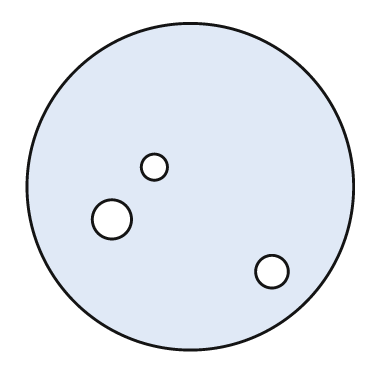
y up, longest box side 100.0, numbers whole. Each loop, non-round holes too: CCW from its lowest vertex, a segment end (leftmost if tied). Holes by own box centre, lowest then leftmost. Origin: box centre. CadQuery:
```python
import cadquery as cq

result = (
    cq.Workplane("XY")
    .moveTo(0.0, 0.0)
    .circle(50.0)
    .moveTo(25.0, -26.0)
    .circle(5.0)
    .moveTo(-24.0, -10.0)
    .circle(6.0)
    .moveTo(-11.0, 6.0)
    .circle(4.0)
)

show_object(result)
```